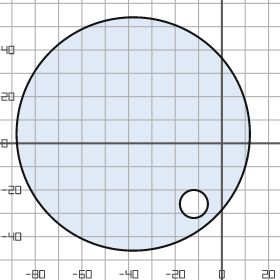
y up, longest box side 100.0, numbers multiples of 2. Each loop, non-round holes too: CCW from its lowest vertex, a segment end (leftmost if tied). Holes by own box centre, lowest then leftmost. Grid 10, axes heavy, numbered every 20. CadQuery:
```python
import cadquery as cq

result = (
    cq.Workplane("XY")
    .moveTo(-38.0, 4.0)
    .circle(50.0)
    .moveTo(-12.0, -26.0)
    .circle(6.0)
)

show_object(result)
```